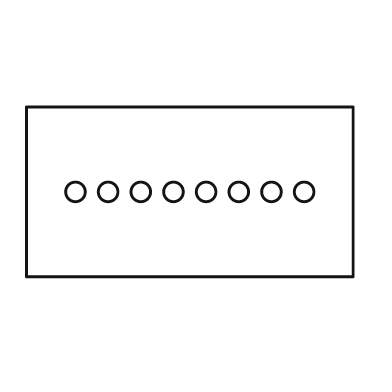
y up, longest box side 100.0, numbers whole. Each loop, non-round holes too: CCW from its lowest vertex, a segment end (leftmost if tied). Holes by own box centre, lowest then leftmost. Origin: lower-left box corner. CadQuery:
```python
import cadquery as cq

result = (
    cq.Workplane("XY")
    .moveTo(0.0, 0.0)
    .lineTo(100.0, 0.0)
    .lineTo(100.0, 52.0)
    .lineTo(0.0, 52.0)
    .close()
    .moveTo(15.0, 26.0)
    .circle(3.0)
    .moveTo(25.0, 26.0)
    .circle(3.0)
    .moveTo(35.0, 26.0)
    .circle(3.0)
    .moveTo(45.0, 26.0)
    .circle(3.0)
    .moveTo(55.0, 26.0)
    .circle(3.0)
    .moveTo(65.0, 26.0)
    .circle(3.0)
    .moveTo(75.0, 26.0)
    .circle(3.0)
    .moveTo(85.0, 26.0)
    .circle(3.0)
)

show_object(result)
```